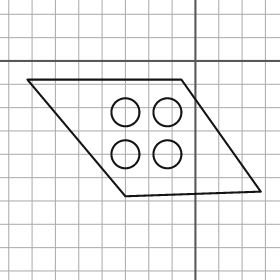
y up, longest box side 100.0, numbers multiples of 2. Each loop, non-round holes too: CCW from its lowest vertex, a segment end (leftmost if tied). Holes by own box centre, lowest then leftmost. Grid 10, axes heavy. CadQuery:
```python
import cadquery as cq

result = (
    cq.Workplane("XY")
    .moveTo(-30.0, -58.0)
    .lineTo(28.0, -56.0)
    .lineTo(-6.0, -8.0)
    .lineTo(-72.0, -8.0)
    .close()
    .moveTo(-30.0, -40.0)
    .circle(6.0)
    .moveTo(-12.0, -40.0)
    .circle(6.0)
    .moveTo(-30.0, -22.0)
    .circle(6.0)
    .moveTo(-12.0, -22.0)
    .circle(6.0)
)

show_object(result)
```